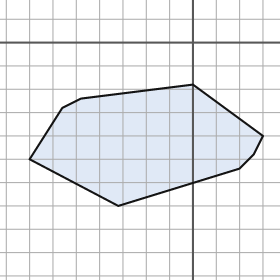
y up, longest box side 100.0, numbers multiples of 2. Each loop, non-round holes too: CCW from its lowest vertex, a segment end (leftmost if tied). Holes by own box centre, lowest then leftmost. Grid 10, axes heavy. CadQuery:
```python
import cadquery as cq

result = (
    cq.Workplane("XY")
    .moveTo(-32.0, -70.0)
    .lineTo(20.0, -54.0)
    .lineTo(26.0, -48.0)
    .lineTo(30.0, -40.0)
    .lineTo(0.0, -18.0)
    .lineTo(-48.0, -24.0)
    .lineTo(-56.0, -28.0)
    .lineTo(-70.0, -50.0)
    .close()
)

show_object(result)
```